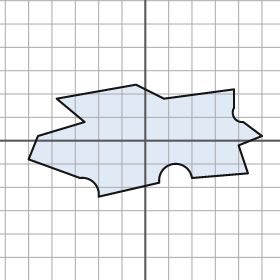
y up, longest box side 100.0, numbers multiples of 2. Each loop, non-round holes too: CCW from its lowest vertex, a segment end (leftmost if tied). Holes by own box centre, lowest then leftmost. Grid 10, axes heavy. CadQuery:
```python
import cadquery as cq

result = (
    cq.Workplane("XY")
    .moveTo(-20.0, -24.0)
    .lineTo(6.0, -18.0)
    .threePointArc((12.0, -10.0), (20.0, -16.0))
    .lineTo(44.0, -14.0)
    .lineTo(40.0, -2.0)
    .lineTo(50.0, 2.0)
    .lineTo(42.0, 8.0)
    .threePointArc((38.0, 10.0), (38.0, 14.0))
    .lineTo(38.0, 22.0)
    .lineTo(8.0, 18.0)
    .lineTo(-4.0, 24.0)
    .lineTo(-38.0, 18.0)
    .lineTo(-26.0, 8.0)
    .lineTo(-46.0, 2.0)
    .lineTo(-50.0, -8.0)
    .lineTo(-28.0, -16.0)
    .threePointArc((-22.0, -18.0), (-20.0, -24.0))
    .close()
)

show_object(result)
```